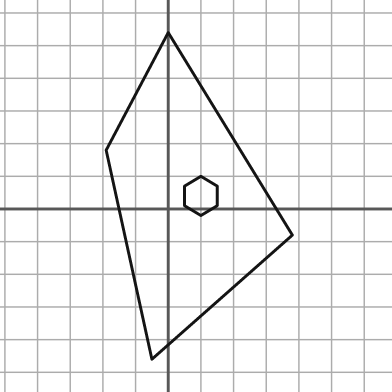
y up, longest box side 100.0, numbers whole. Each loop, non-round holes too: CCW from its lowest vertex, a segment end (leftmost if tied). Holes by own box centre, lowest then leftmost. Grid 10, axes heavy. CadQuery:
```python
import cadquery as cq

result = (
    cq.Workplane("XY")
    .moveTo(-5.0, -46.0)
    .lineTo(38.0, -8.0)
    .lineTo(0.0, 54.0)
    .lineTo(-19.0, 18.0)
    .close()
    .moveTo(10.0, -2.0)
    .lineTo(15.0, 1.0)
    .lineTo(15.0, 7.0)
    .lineTo(10.0, 10.0)
    .lineTo(5.0, 7.0)
    .lineTo(5.0, 1.0)
    .close()
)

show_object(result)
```